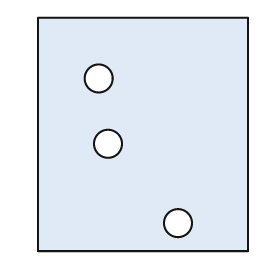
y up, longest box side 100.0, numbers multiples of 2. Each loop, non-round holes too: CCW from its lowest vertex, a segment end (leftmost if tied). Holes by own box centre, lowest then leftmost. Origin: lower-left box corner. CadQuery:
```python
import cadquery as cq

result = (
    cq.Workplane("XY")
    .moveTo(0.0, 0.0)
    .lineTo(90.0, 0.0)
    .lineTo(90.0, 100.0)
    .lineTo(0.0, 100.0)
    .close()
    .moveTo(60.0, 12.0)
    .circle(6.0)
    .moveTo(30.0, 46.0)
    .circle(6.0)
    .moveTo(26.0, 74.0)
    .circle(6.0)
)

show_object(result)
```